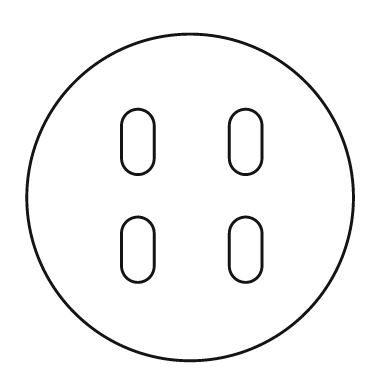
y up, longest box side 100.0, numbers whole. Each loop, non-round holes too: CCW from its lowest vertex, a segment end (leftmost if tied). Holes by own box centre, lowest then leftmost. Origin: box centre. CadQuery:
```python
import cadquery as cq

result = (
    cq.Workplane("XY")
    .moveTo(0.0, 0.0)
    .circle(50.0)
    .moveTo(-21.0, -21.0)
    .threePointArc((-16.0, -26.0), (-11.0, -21.0))
    .lineTo(-11.0, -11.0)
    .threePointArc((-16.0, -6.0), (-21.0, -11.0))
    .close()
    .moveTo(12.0, -21.0)
    .threePointArc((17.0, -26.0), (22.0, -21.0))
    .lineTo(22.0, -11.0)
    .threePointArc((17.0, -6.0), (12.0, -11.0))
    .close()
    .moveTo(-21.0, 12.0)
    .threePointArc((-16.0, 7.0), (-11.0, 12.0))
    .lineTo(-11.0, 22.0)
    .threePointArc((-16.0, 27.0), (-21.0, 22.0))
    .close()
    .moveTo(12.0, 12.0)
    .threePointArc((17.0, 7.0), (22.0, 12.0))
    .lineTo(22.0, 22.0)
    .threePointArc((17.0, 27.0), (12.0, 22.0))
    .close()
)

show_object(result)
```